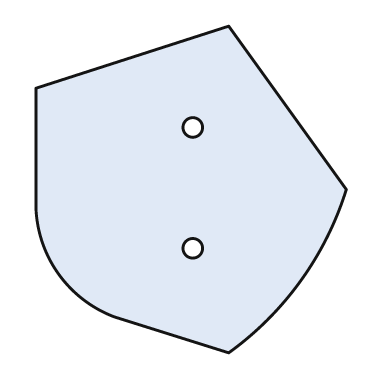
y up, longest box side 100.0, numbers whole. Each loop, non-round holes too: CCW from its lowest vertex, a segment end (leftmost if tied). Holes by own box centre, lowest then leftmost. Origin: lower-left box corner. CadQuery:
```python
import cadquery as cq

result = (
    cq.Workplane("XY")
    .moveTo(59.0, 0.0)
    .threePointArc((81.0, 22.0), (95.0, 50.0))
    .lineTo(59.0, 100.0)
    .lineTo(0.0, 81.0)
    .lineTo(0.0, 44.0)
    .threePointArc((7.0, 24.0), (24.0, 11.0))
    .close()
    .moveTo(48.0, 32.0)
    .circle(3.0)
    .moveTo(48.0, 69.0)
    .circle(3.0)
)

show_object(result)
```